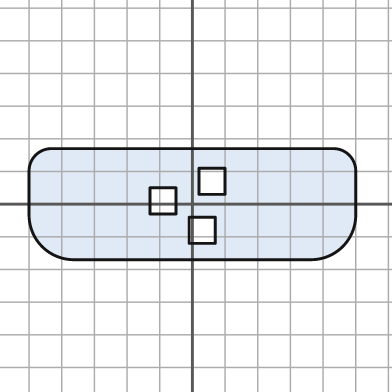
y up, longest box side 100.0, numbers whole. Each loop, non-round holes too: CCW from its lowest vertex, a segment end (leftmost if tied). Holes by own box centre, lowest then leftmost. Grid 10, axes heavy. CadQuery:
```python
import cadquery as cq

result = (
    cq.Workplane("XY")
    .moveTo(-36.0, -17.0)
    .lineTo(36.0, -17.0)
    .threePointArc((46.0, -13.0), (50.0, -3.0))
    .lineTo(50.0, 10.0)
    .threePointArc((48.0, 15.0), (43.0, 17.0))
    .lineTo(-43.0, 17.0)
    .threePointArc((-48.0, 15.0), (-50.0, 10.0))
    .lineTo(-50.0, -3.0)
    .threePointArc((-46.0, -13.0), (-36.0, -17.0))
    .close()
    .moveTo(-1.0, -12.0)
    .lineTo(7.0, -12.0)
    .lineTo(7.0, -4.0)
    .lineTo(-1.0, -4.0)
    .close()
    .moveTo(-13.0, -3.0)
    .lineTo(-5.0, -3.0)
    .lineTo(-5.0, 5.0)
    .lineTo(-13.0, 5.0)
    .close()
    .moveTo(2.0, 3.0)
    .lineTo(10.0, 3.0)
    .lineTo(10.0, 11.0)
    .lineTo(2.0, 11.0)
    .close()
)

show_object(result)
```